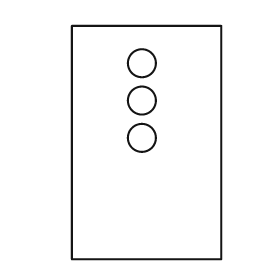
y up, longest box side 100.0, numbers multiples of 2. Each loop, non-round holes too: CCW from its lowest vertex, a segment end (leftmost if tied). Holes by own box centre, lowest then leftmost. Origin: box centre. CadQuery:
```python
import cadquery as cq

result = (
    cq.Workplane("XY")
    .moveTo(-32.0, -50.0)
    .lineTo(32.0, -50.0)
    .lineTo(32.0, 50.0)
    .lineTo(-32.0, 50.0)
    .close()
    .moveTo(-2.0, 2.0)
    .circle(6.0)
    .moveTo(-2.0, 18.0)
    .circle(6.0)
    .moveTo(-2.0, 34.0)
    .circle(6.0)
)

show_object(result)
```